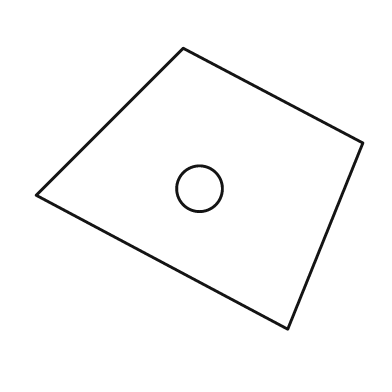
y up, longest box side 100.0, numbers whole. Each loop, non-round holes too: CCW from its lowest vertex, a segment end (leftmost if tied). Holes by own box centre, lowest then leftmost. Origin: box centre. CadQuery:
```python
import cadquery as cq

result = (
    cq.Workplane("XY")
    .moveTo(27.0, -43.0)
    .lineTo(50.0, 14.0)
    .lineTo(-5.0, 43.0)
    .lineTo(-50.0, -2.0)
    .close()
    .moveTo(0.0, 0.0)
    .circle(7.0)
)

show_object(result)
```